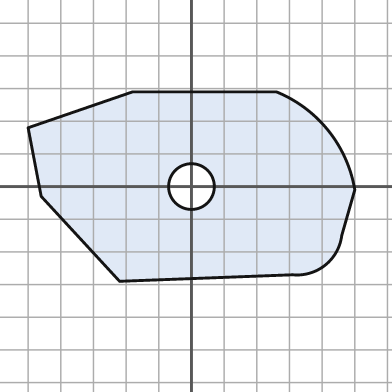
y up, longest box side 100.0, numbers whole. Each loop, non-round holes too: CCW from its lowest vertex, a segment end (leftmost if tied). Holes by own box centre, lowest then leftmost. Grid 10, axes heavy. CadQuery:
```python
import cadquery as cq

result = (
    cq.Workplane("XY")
    .moveTo(-22.0, -29.0)
    .lineTo(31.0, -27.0)
    .threePointArc((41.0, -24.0), (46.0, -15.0))
    .lineTo(50.0, -1.0)
    .threePointArc((42.0, 17.0), (26.0, 29.0))
    .lineTo(-18.0, 29.0)
    .lineTo(-50.0, 18.0)
    .lineTo(-46.0, -3.0)
    .close()
    .moveTo(0.0, 0.0)
    .circle(7.0)
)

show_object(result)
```